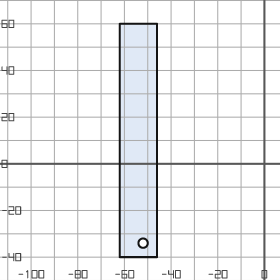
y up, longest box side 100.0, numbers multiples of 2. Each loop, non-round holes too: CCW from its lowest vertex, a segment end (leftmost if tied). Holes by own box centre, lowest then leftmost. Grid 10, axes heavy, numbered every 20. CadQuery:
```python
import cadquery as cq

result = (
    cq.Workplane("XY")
    .moveTo(-62.0, -40.0)
    .lineTo(-46.0, -40.0)
    .lineTo(-46.0, 60.0)
    .lineTo(-62.0, 60.0)
    .close()
    .moveTo(-52.0, -34.0)
    .circle(2.0)
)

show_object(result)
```